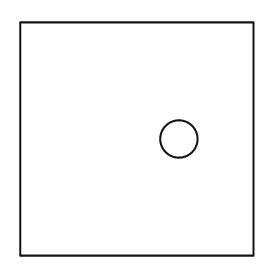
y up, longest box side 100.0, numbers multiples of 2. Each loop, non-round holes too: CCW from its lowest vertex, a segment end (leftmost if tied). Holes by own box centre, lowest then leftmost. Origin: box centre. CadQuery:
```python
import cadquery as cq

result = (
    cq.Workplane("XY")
    .moveTo(-50.0, -50.0)
    .lineTo(50.0, -50.0)
    .lineTo(50.0, 50.0)
    .lineTo(-50.0, 50.0)
    .close()
    .moveTo(18.0, 0.0)
    .circle(8.0)
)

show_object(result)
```